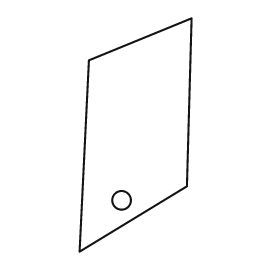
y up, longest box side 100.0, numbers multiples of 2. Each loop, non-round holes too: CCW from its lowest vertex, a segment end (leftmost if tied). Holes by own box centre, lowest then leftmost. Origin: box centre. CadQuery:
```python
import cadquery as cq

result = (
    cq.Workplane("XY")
    .moveTo(-24.0, -50.0)
    .lineTo(22.0, -22.0)
    .lineTo(24.0, 50.0)
    .lineTo(-20.0, 32.0)
    .close()
    .moveTo(-6.0, -28.0)
    .circle(4.0)
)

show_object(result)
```